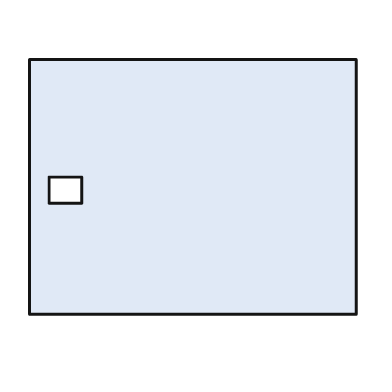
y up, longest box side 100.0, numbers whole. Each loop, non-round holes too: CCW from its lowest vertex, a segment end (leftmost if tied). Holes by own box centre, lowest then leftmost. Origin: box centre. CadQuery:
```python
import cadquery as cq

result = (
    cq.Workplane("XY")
    .moveTo(-50.0, -39.0)
    .lineTo(50.0, -39.0)
    .lineTo(50.0, 39.0)
    .lineTo(-50.0, 39.0)
    .close()
    .moveTo(-44.0, -5.0)
    .lineTo(-34.0, -5.0)
    .lineTo(-34.0, 3.0)
    .lineTo(-44.0, 3.0)
    .close()
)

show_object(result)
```